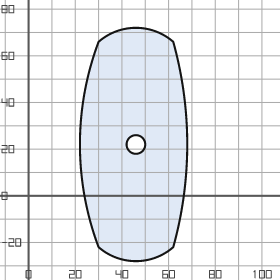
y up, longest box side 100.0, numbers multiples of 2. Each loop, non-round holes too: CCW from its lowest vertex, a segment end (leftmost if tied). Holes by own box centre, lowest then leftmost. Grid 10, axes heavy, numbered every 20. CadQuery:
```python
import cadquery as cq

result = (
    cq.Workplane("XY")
    .moveTo(30.0, -22.0)
    .threePointArc((46.0, -28.0), (62.0, -22.0))
    .threePointArc((68.0, 22.0), (62.0, 66.0))
    .threePointArc((46.0, 72.0), (30.0, 66.0))
    .threePointArc((22.0, 22.0), (30.0, -22.0))
    .close()
    .moveTo(46.0, 22.0)
    .circle(4.0)
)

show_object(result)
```